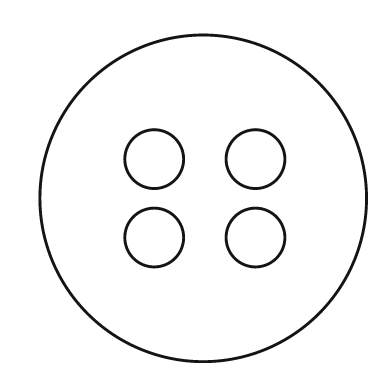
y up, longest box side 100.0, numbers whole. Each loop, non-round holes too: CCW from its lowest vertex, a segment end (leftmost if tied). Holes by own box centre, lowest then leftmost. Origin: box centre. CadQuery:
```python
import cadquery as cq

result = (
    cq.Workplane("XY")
    .moveTo(0.0, 0.0)
    .circle(50.0)
    .moveTo(-15.0, -12.0)
    .circle(9.0)
    .moveTo(16.0, -12.0)
    .circle(9.0)
    .moveTo(-15.0, 12.0)
    .circle(9.0)
    .moveTo(16.0, 12.0)
    .circle(9.0)
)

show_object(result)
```